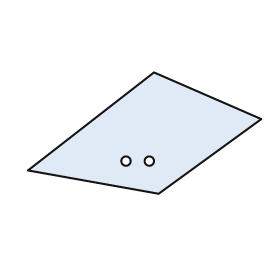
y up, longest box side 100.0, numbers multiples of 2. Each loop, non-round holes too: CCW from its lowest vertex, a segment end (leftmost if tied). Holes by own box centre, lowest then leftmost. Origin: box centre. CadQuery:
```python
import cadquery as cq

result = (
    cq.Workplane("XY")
    .moveTo(6.0, -26.0)
    .lineTo(50.0, 6.0)
    .lineTo(4.0, 26.0)
    .lineTo(-50.0, -16.0)
    .close()
    .moveTo(-8.0, -12.0)
    .circle(2.0)
    .moveTo(2.0, -12.0)
    .circle(2.0)
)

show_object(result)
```